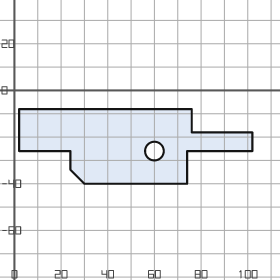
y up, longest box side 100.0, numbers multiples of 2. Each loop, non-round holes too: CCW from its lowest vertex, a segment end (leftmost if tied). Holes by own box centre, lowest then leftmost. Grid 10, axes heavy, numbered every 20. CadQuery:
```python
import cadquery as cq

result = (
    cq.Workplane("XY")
    .moveTo(30.0, -40.0)
    .lineTo(74.0, -40.0)
    .lineTo(74.0, -26.0)
    .lineTo(102.0, -26.0)
    .lineTo(102.0, -18.0)
    .lineTo(76.0, -18.0)
    .lineTo(76.0, -8.0)
    .lineTo(2.0, -8.0)
    .lineTo(2.0, -26.0)
    .lineTo(24.0, -26.0)
    .lineTo(24.0, -34.0)
    .close()
    .moveTo(60.0, -26.0)
    .circle(4.0)
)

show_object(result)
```